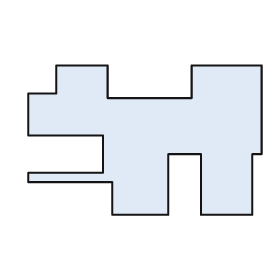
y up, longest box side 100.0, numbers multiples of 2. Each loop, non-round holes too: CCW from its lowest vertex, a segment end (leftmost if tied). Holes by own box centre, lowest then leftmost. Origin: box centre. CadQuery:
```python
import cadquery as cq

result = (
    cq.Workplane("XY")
    .moveTo(-14.0, -32.0)
    .lineTo(10.0, -32.0)
    .lineTo(10.0, -6.0)
    .lineTo(24.0, -6.0)
    .lineTo(24.0, -32.0)
    .lineTo(46.0, -32.0)
    .lineTo(46.0, -6.0)
    .lineTo(50.0, -6.0)
    .lineTo(50.0, 32.0)
    .lineTo(20.0, 32.0)
    .lineTo(20.0, 18.0)
    .lineTo(-16.0, 18.0)
    .lineTo(-16.0, 32.0)
    .lineTo(-38.0, 32.0)
    .lineTo(-38.0, 20.0)
    .lineTo(-50.0, 20.0)
    .lineTo(-50.0, 2.0)
    .lineTo(-18.0, 2.0)
    .lineTo(-18.0, -14.0)
    .lineTo(-50.0, -14.0)
    .lineTo(-50.0, -18.0)
    .lineTo(-14.0, -18.0)
    .close()
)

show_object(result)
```